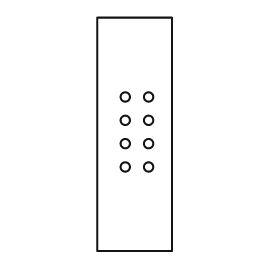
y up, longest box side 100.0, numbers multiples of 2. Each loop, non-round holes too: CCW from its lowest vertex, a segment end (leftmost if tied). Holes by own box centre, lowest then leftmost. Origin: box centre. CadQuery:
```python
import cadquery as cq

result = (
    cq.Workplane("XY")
    .moveTo(-16.0, -50.0)
    .lineTo(16.0, -50.0)
    .lineTo(16.0, 50.0)
    .lineTo(-16.0, 50.0)
    .close()
    .moveTo(-4.0, -14.0)
    .circle(2.0)
    .moveTo(6.0, -14.0)
    .circle(2.0)
    .moveTo(-4.0, -4.0)
    .circle(2.0)
    .moveTo(6.0, -4.0)
    .circle(2.0)
    .moveTo(-4.0, 6.0)
    .circle(2.0)
    .moveTo(6.0, 6.0)
    .circle(2.0)
    .moveTo(-4.0, 16.0)
    .circle(2.0)
    .moveTo(6.0, 16.0)
    .circle(2.0)
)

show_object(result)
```